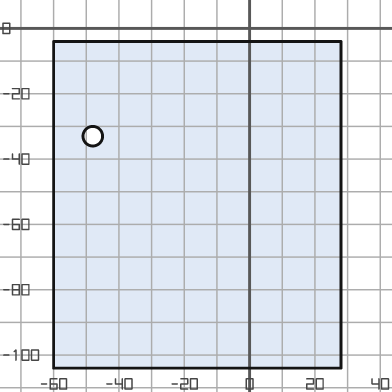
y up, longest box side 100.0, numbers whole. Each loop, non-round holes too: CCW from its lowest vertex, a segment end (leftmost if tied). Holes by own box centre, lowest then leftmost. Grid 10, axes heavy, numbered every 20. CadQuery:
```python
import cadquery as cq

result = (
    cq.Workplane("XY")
    .moveTo(-60.0, -104.0)
    .lineTo(28.0, -104.0)
    .lineTo(28.0, -4.0)
    .lineTo(-60.0, -4.0)
    .close()
    .moveTo(-48.0, -33.0)
    .circle(3.0)
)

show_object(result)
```